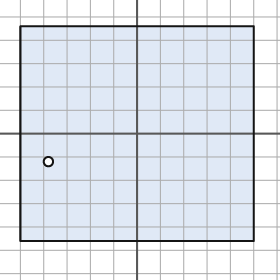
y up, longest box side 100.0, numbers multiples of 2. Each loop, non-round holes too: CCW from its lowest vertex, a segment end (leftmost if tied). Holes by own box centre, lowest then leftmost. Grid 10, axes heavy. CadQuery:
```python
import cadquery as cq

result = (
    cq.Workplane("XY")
    .moveTo(-50.0, -46.0)
    .lineTo(50.0, -46.0)
    .lineTo(50.0, 46.0)
    .lineTo(-50.0, 46.0)
    .close()
    .moveTo(-38.0, -12.0)
    .circle(2.0)
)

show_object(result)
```